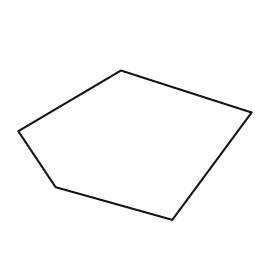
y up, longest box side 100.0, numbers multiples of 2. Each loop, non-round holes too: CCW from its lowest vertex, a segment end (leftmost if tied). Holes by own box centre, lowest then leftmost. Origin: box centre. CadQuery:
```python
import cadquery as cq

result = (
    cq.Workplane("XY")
    .moveTo(16.0, -32.0)
    .lineTo(50.0, 14.0)
    .lineTo(-6.0, 32.0)
    .lineTo(-50.0, 6.0)
    .lineTo(-34.0, -18.0)
    .close()
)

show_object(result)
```